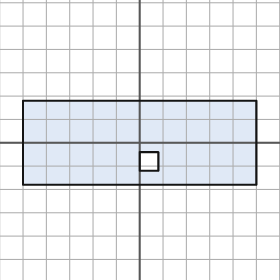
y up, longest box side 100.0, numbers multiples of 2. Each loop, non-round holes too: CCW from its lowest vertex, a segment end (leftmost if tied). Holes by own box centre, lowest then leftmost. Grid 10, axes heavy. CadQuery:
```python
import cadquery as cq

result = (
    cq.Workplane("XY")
    .moveTo(-50.0, -18.0)
    .lineTo(50.0, -18.0)
    .lineTo(50.0, 18.0)
    .lineTo(-50.0, 18.0)
    .close()
    .moveTo(0.0, -12.0)
    .lineTo(8.0, -12.0)
    .lineTo(8.0, -4.0)
    .lineTo(0.0, -4.0)
    .close()
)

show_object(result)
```